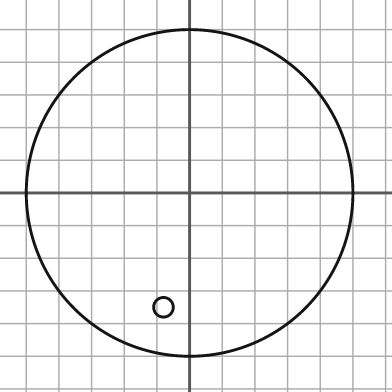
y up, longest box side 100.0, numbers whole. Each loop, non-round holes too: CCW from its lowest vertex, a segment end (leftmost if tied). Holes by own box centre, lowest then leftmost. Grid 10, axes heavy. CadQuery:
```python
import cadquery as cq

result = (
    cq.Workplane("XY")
    .moveTo(0.0, 0.0)
    .circle(50.0)
    .moveTo(-8.0, -35.0)
    .circle(3.0)
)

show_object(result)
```